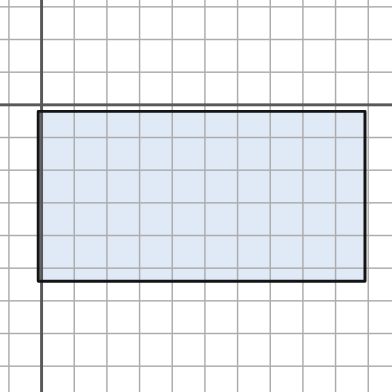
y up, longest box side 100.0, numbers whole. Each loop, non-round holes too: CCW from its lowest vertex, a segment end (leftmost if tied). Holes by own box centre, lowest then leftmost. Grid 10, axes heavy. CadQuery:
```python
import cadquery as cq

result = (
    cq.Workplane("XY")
    .moveTo(-1.0, -54.0)
    .lineTo(99.0, -54.0)
    .lineTo(99.0, -2.0)
    .lineTo(-1.0, -2.0)
    .close()
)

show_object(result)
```